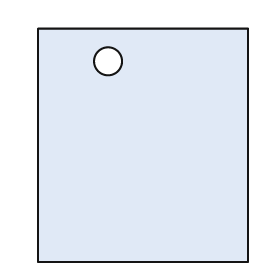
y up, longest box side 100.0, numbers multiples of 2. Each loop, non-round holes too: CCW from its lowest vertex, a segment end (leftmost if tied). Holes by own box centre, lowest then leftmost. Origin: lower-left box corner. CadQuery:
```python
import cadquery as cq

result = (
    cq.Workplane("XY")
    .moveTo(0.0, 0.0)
    .lineTo(90.0, 0.0)
    .lineTo(90.0, 100.0)
    .lineTo(0.0, 100.0)
    .close()
    .moveTo(30.0, 86.0)
    .circle(6.0)
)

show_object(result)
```